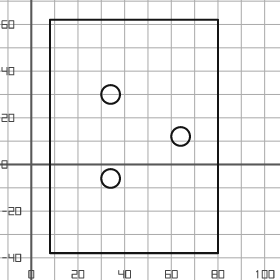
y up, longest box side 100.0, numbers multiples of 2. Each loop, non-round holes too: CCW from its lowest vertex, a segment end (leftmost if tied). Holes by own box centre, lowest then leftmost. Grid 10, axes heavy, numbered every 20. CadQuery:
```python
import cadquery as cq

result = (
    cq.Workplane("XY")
    .moveTo(8.0, -38.0)
    .lineTo(80.0, -38.0)
    .lineTo(80.0, 62.0)
    .lineTo(8.0, 62.0)
    .close()
    .moveTo(34.0, -6.0)
    .circle(4.0)
    .moveTo(64.0, 12.0)
    .circle(4.0)
    .moveTo(34.0, 30.0)
    .circle(4.0)
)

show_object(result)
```